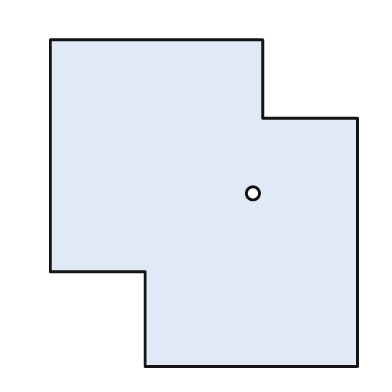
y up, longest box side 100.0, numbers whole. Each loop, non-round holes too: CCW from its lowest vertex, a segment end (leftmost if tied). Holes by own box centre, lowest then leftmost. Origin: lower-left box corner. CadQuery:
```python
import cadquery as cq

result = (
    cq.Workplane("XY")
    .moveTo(29.0, 0.0)
    .lineTo(94.0, 0.0)
    .lineTo(94.0, 76.0)
    .lineTo(65.0, 76.0)
    .lineTo(65.0, 100.0)
    .lineTo(0.0, 100.0)
    .lineTo(0.0, 29.0)
    .lineTo(29.0, 29.0)
    .close()
    .moveTo(62.0, 53.0)
    .circle(2.0)
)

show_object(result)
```